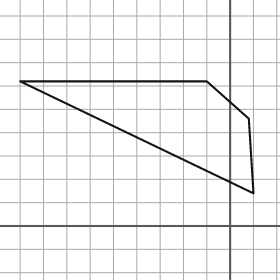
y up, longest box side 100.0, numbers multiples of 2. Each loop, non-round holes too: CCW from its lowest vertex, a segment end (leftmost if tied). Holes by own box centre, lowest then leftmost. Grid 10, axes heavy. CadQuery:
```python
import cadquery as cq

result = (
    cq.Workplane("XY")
    .moveTo(10.0, 14.0)
    .lineTo(8.0, 46.0)
    .lineTo(-10.0, 62.0)
    .lineTo(-90.0, 62.0)
    .close()
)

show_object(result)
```